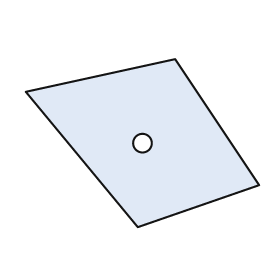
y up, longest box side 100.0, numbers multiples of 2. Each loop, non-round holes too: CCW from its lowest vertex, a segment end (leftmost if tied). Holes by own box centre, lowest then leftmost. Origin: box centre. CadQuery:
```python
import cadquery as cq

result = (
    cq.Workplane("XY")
    .moveTo(-2.0, -36.0)
    .lineTo(50.0, -18.0)
    .lineTo(14.0, 36.0)
    .lineTo(-50.0, 22.0)
    .close()
    .moveTo(0.0, 0.0)
    .circle(4.0)
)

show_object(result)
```